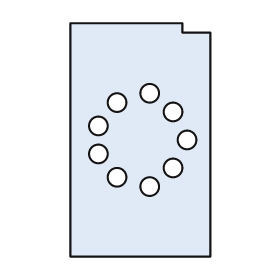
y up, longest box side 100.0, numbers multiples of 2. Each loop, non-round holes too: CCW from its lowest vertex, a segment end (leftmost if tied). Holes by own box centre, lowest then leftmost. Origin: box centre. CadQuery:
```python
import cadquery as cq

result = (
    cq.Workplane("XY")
    .moveTo(-30.0, -50.0)
    .lineTo(30.0, -50.0)
    .lineTo(30.0, 46.0)
    .lineTo(18.0, 46.0)
    .lineTo(18.0, 50.0)
    .lineTo(-30.0, 50.0)
    .close()
    .moveTo(4.0, -20.0)
    .circle(4.0)
    .moveTo(-10.0, -16.0)
    .circle(4.0)
    .moveTo(14.0, -12.0)
    .circle(4.0)
    .moveTo(-18.0, -6.0)
    .circle(4.0)
    .moveTo(20.0, 0.0)
    .circle(4.0)
    .moveTo(-18.0, 6.0)
    .circle(4.0)
    .moveTo(14.0, 12.0)
    .circle(4.0)
    .moveTo(-10.0, 16.0)
    .circle(4.0)
    .moveTo(4.0, 20.0)
    .circle(4.0)
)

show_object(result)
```